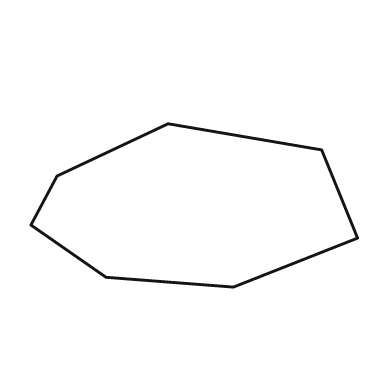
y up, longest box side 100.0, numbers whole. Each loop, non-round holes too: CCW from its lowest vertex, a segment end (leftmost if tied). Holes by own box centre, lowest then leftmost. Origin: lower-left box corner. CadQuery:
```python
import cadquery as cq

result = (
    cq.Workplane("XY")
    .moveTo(62.0, 0.0)
    .lineTo(100.0, 15.0)
    .lineTo(89.0, 42.0)
    .lineTo(42.0, 50.0)
    .lineTo(8.0, 34.0)
    .lineTo(0.0, 19.0)
    .lineTo(23.0, 3.0)
    .close()
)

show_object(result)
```